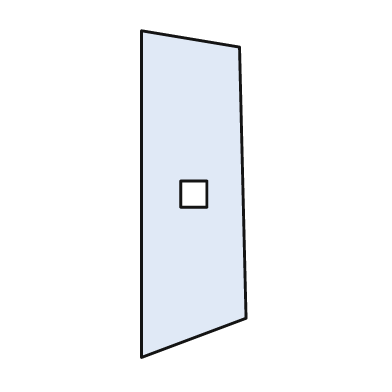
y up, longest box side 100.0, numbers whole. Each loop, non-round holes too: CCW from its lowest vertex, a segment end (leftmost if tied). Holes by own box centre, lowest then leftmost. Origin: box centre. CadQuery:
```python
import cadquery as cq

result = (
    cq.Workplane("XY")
    .moveTo(-16.0, -50.0)
    .lineTo(16.0, -38.0)
    .lineTo(14.0, 45.0)
    .lineTo(-16.0, 50.0)
    .close()
    .moveTo(-4.0, -4.0)
    .lineTo(4.0, -4.0)
    .lineTo(4.0, 4.0)
    .lineTo(-4.0, 4.0)
    .close()
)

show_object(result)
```